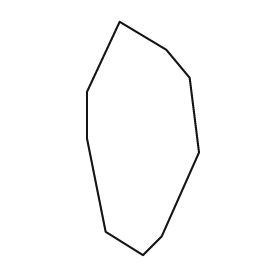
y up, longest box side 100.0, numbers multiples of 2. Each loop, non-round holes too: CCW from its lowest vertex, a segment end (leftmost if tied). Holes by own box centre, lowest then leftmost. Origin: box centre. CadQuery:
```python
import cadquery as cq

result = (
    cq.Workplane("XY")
    .moveTo(0.0, -50.0)
    .lineTo(8.0, -42.0)
    .lineTo(24.0, -6.0)
    .lineTo(20.0, 26.0)
    .lineTo(10.0, 38.0)
    .lineTo(-10.0, 50.0)
    .lineTo(-24.0, 20.0)
    .lineTo(-24.0, 0.0)
    .lineTo(-16.0, -40.0)
    .close()
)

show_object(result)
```